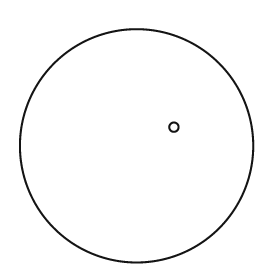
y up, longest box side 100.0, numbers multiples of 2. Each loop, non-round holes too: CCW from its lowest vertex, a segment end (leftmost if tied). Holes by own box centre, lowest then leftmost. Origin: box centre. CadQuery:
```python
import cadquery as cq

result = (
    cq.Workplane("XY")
    .moveTo(0.0, 0.0)
    .circle(50.0)
    .moveTo(16.0, 8.0)
    .circle(2.0)
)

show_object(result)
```